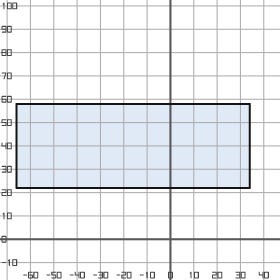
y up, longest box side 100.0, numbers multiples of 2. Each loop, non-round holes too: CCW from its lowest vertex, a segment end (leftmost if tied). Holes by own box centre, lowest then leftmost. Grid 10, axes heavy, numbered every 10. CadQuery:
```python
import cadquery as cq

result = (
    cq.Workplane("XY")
    .moveTo(-66.0, 22.0)
    .lineTo(34.0, 22.0)
    .lineTo(34.0, 58.0)
    .lineTo(-66.0, 58.0)
    .close()
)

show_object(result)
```